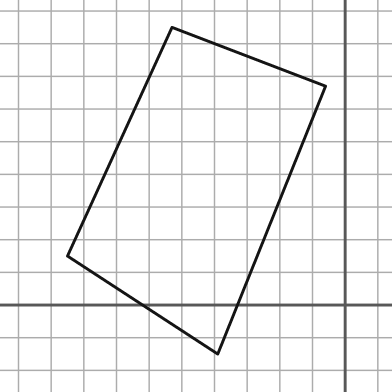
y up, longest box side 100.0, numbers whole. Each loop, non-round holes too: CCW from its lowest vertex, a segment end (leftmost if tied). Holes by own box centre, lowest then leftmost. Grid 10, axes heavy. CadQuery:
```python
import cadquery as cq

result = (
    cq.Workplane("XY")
    .moveTo(-39.0, -15.0)
    .lineTo(-6.0, 67.0)
    .lineTo(-53.0, 85.0)
    .lineTo(-85.0, 15.0)
    .close()
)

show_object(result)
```